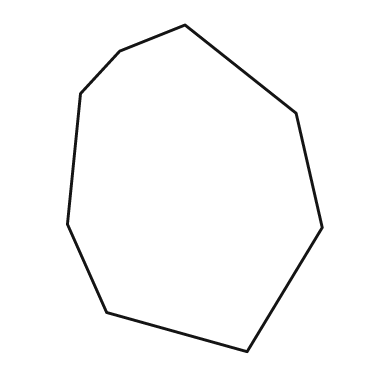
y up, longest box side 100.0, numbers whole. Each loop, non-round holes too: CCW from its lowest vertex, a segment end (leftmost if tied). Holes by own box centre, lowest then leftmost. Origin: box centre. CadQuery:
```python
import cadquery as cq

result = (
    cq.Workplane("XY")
    .moveTo(16.0, -50.0)
    .lineTo(39.0, -12.0)
    .lineTo(31.0, 23.0)
    .lineTo(-3.0, 50.0)
    .lineTo(-23.0, 42.0)
    .lineTo(-35.0, 29.0)
    .lineTo(-39.0, -11.0)
    .lineTo(-27.0, -38.0)
    .close()
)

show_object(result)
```